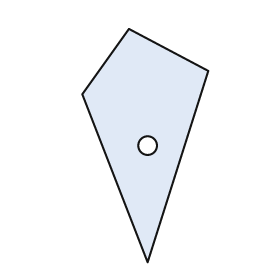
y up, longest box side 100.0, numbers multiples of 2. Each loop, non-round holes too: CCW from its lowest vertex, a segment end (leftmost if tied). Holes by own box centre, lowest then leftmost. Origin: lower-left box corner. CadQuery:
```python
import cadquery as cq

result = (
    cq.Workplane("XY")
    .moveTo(28.0, 0.0)
    .lineTo(54.0, 82.0)
    .lineTo(20.0, 100.0)
    .lineTo(0.0, 72.0)
    .close()
    .moveTo(28.0, 50.0)
    .circle(4.0)
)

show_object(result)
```